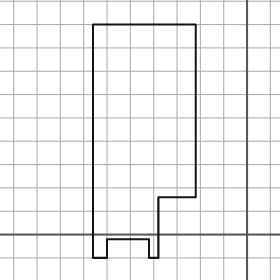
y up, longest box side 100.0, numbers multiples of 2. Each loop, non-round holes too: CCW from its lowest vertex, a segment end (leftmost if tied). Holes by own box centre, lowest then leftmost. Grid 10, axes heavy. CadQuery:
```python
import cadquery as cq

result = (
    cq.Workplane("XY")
    .moveTo(-66.0, -10.0)
    .lineTo(-60.0, -10.0)
    .lineTo(-60.0, -2.0)
    .lineTo(-42.0, -2.0)
    .lineTo(-42.0, -10.0)
    .lineTo(-38.0, -10.0)
    .lineTo(-38.0, 16.0)
    .lineTo(-22.0, 16.0)
    .lineTo(-22.0, 90.0)
    .lineTo(-66.0, 90.0)
    .close()
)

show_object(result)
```